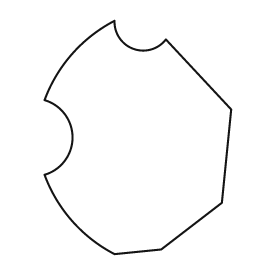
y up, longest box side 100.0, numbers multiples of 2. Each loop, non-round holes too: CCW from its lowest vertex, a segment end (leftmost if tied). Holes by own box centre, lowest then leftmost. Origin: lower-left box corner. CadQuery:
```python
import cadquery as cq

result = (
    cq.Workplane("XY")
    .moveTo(30.0, 0.0)
    .lineTo(50.0, 2.0)
    .lineTo(76.0, 22.0)
    .lineTo(80.0, 62.0)
    .lineTo(52.0, 92.0)
    .threePointArc((38.0, 88.0), (30.0, 100.0))
    .threePointArc((12.0, 86.0), (0.0, 66.0))
    .threePointArc((12.0, 50.0), (0.0, 34.0))
    .threePointArc((12.0, 14.0), (30.0, 0.0))
    .close()
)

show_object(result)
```